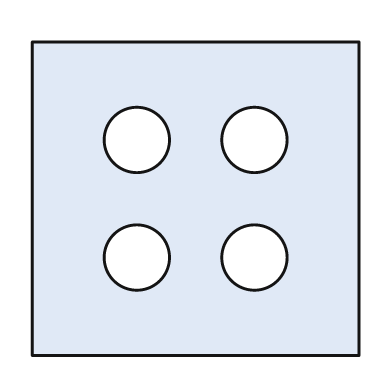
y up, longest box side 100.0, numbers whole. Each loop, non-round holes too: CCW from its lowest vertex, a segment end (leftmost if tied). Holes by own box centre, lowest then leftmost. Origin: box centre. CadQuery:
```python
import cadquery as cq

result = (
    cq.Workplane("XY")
    .moveTo(-50.0, -48.0)
    .lineTo(50.0, -48.0)
    .lineTo(50.0, 48.0)
    .lineTo(-50.0, 48.0)
    .close()
    .moveTo(-18.0, -18.0)
    .circle(10.0)
    .moveTo(18.0, -18.0)
    .circle(10.0)
    .moveTo(-18.0, 18.0)
    .circle(10.0)
    .moveTo(18.0, 18.0)
    .circle(10.0)
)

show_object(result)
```